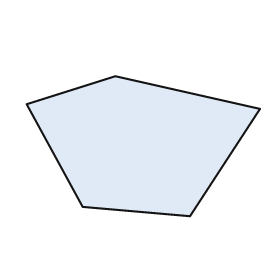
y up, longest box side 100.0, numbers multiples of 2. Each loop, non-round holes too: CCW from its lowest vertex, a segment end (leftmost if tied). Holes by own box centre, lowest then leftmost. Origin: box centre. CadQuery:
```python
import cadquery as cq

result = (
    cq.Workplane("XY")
    .moveTo(20.0, -30.0)
    .lineTo(50.0, 16.0)
    .lineTo(-12.0, 30.0)
    .lineTo(-50.0, 18.0)
    .lineTo(-26.0, -26.0)
    .close()
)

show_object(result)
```